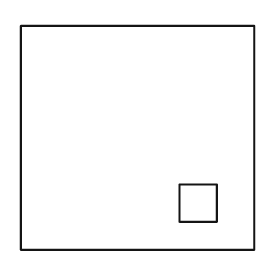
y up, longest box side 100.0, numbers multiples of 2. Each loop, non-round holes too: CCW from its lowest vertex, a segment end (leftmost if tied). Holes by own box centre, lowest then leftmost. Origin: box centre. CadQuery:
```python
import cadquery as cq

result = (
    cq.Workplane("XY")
    .moveTo(-50.0, -48.0)
    .lineTo(50.0, -48.0)
    .lineTo(50.0, 48.0)
    .lineTo(-50.0, 48.0)
    .close()
    .moveTo(18.0, -36.0)
    .lineTo(34.0, -36.0)
    .lineTo(34.0, -20.0)
    .lineTo(18.0, -20.0)
    .close()
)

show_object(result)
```